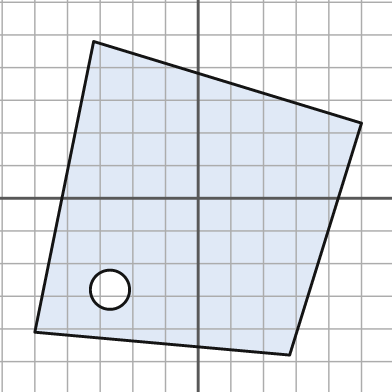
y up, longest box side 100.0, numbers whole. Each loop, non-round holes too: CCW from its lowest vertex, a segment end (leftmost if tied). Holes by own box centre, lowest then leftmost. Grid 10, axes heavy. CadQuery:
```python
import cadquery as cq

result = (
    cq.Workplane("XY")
    .moveTo(28.0, -48.0)
    .lineTo(50.0, 23.0)
    .lineTo(-32.0, 48.0)
    .lineTo(-50.0, -41.0)
    .close()
    .moveTo(-27.0, -28.0)
    .circle(6.0)
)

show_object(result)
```